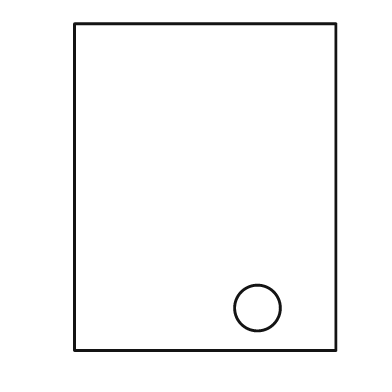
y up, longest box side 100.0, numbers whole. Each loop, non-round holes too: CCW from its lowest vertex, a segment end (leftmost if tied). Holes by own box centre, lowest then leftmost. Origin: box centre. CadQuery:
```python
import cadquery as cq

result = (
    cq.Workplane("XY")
    .moveTo(-40.0, -50.0)
    .lineTo(40.0, -50.0)
    .lineTo(40.0, 50.0)
    .lineTo(-40.0, 50.0)
    .close()
    .moveTo(16.0, -37.0)
    .circle(7.0)
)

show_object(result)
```